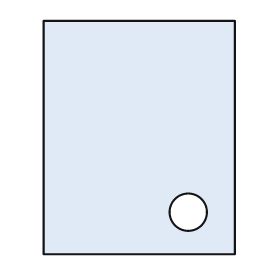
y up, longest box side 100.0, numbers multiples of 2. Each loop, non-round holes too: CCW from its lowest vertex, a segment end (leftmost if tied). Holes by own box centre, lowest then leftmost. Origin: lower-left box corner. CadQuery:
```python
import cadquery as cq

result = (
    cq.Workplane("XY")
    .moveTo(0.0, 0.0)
    .lineTo(82.0, 0.0)
    .lineTo(82.0, 100.0)
    .lineTo(0.0, 100.0)
    .close()
    .moveTo(62.0, 18.0)
    .circle(8.0)
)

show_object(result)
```